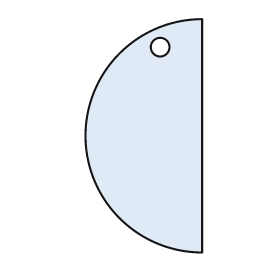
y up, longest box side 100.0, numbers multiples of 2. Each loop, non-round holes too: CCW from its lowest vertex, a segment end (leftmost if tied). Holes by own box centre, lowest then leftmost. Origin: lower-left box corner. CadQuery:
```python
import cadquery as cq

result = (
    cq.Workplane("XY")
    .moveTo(50.0, 0.0)
    .lineTo(50.0, 100.0)
    .threePointArc((0.0, 50.0), (50.0, 0.0))
    .close()
    .moveTo(32.0, 88.0)
    .circle(4.0)
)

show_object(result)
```